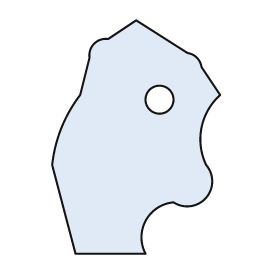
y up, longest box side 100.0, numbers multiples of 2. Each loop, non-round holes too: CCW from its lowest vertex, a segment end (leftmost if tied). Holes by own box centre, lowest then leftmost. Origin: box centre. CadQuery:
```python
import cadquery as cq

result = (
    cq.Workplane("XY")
    .moveTo(-26.0, -50.0)
    .lineTo(4.0, -50.0)
    .threePointArc((4.0, -36.0), (16.0, -28.0))
    .threePointArc((30.0, -26.0), (30.0, -12.0))
    .threePointArc((28.0, 4.0), (36.0, 18.0))
    .lineTo(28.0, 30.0)
    .threePointArc((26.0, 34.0), (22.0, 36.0))
    .lineTo(0.0, 50.0)
    .lineTo(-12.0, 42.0)
    .threePointArc((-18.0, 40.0), (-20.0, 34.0))
    .lineTo(-24.0, 18.0)
    .threePointArc((-32.0, 4.0), (-36.0, -12.0))
    .close()
    .moveTo(10.0, 16.0)
    .circle(6.0)
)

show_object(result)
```